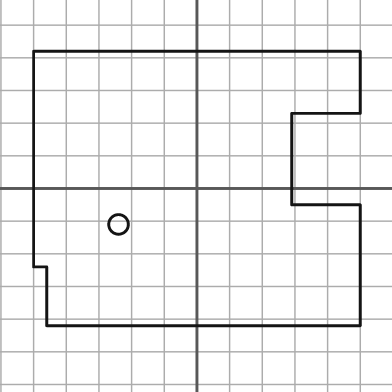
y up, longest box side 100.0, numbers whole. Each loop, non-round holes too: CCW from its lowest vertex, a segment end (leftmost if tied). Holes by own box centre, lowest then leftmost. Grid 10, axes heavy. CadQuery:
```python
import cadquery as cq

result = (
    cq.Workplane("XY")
    .moveTo(-46.0, -42.0)
    .lineTo(50.0, -42.0)
    .lineTo(50.0, -5.0)
    .lineTo(29.0, -5.0)
    .lineTo(29.0, 23.0)
    .lineTo(50.0, 23.0)
    .lineTo(50.0, 42.0)
    .lineTo(-50.0, 42.0)
    .lineTo(-50.0, -24.0)
    .lineTo(-46.0, -24.0)
    .close()
    .moveTo(-24.0, -11.0)
    .circle(3.0)
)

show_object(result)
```